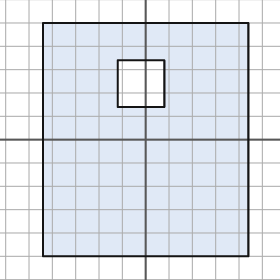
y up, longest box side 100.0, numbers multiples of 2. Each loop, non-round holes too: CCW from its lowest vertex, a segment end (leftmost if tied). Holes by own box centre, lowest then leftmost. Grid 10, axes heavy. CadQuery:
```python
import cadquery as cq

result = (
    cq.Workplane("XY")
    .moveTo(-44.0, -50.0)
    .lineTo(44.0, -50.0)
    .lineTo(44.0, 50.0)
    .lineTo(-44.0, 50.0)
    .close()
    .moveTo(-12.0, 14.0)
    .lineTo(8.0, 14.0)
    .lineTo(8.0, 34.0)
    .lineTo(-12.0, 34.0)
    .close()
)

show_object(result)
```